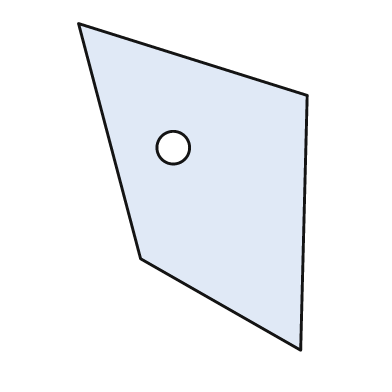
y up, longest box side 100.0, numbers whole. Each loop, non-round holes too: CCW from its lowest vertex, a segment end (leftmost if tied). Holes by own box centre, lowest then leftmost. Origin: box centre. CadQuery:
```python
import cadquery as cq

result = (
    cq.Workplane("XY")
    .moveTo(33.0, -50.0)
    .lineTo(35.0, 28.0)
    .lineTo(-35.0, 50.0)
    .lineTo(-16.0, -22.0)
    .close()
    .moveTo(-6.0, 12.0)
    .circle(5.0)
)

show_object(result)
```